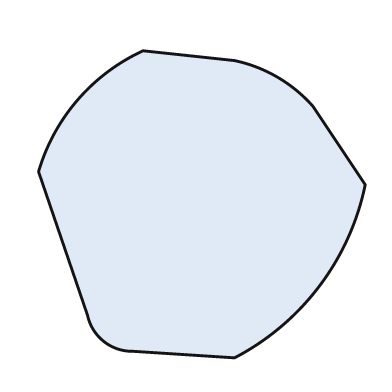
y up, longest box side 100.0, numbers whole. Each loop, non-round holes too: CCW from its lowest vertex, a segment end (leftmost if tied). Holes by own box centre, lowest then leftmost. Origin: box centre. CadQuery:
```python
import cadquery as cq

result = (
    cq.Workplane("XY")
    .moveTo(10.0, -47.0)
    .threePointArc((36.0, -25.0), (50.0, 6.0))
    .lineTo(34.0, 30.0)
    .threePointArc((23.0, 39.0), (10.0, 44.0))
    .lineTo(-18.0, 47.0)
    .threePointArc((-38.0, 32.0), (-50.0, 10.0))
    .lineTo(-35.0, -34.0)
    .threePointArc((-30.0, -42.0), (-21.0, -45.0))
    .close()
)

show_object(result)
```